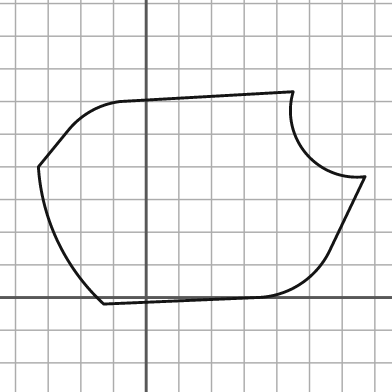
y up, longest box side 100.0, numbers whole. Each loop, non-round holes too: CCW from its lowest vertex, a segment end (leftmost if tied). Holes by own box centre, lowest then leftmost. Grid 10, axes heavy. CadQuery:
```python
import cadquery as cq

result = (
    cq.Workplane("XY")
    .moveTo(-13.0, -2.0)
    .lineTo(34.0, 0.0)
    .threePointArc((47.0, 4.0), (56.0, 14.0))
    .lineTo(67.0, 37.0)
    .threePointArc((49.0, 44.0), (45.0, 63.0))
    .lineTo(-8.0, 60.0)
    .threePointArc((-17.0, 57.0), (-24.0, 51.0))
    .lineTo(-33.0, 40.0)
    .threePointArc((-27.0, 17.0), (-13.0, -2.0))
    .close()
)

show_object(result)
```